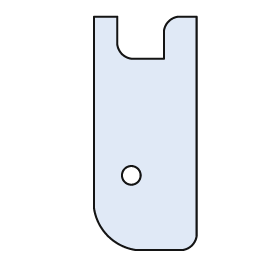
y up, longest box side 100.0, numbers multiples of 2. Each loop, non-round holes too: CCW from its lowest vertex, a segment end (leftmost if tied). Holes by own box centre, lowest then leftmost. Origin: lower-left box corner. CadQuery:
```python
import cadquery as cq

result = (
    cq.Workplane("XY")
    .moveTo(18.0, 0.0)
    .lineTo(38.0, 0.0)
    .threePointArc((42.0, 2.0), (44.0, 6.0))
    .lineTo(44.0, 100.0)
    .lineTo(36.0, 100.0)
    .threePointArc((32.0, 98.0), (30.0, 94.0))
    .lineTo(30.0, 82.0)
    .lineTo(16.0, 82.0)
    .threePointArc((12.0, 84.0), (10.0, 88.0))
    .lineTo(10.0, 100.0)
    .lineTo(0.0, 100.0)
    .lineTo(0.0, 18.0)
    .threePointArc((6.0, 6.0), (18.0, 0.0))
    .close()
    .moveTo(16.0, 32.0)
    .circle(4.0)
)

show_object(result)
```